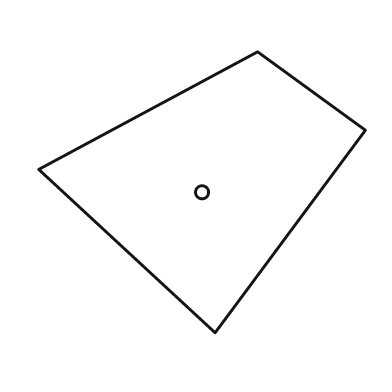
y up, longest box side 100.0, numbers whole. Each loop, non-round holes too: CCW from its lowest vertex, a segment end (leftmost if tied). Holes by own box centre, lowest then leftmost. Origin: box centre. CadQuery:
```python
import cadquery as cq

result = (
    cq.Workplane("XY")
    .moveTo(4.0, -43.0)
    .lineTo(50.0, 19.0)
    .lineTo(17.0, 43.0)
    .lineTo(-50.0, 7.0)
    .close()
    .moveTo(0.0, 0.0)
    .circle(2.0)
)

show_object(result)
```